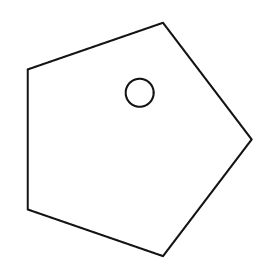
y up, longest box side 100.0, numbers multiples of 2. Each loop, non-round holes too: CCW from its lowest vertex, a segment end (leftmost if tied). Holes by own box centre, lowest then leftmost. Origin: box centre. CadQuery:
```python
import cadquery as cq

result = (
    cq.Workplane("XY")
    .moveTo(10.0, -50.0)
    .lineTo(48.0, 0.0)
    .lineTo(10.0, 50.0)
    .lineTo(-48.0, 30.0)
    .lineTo(-48.0, -30.0)
    .close()
    .moveTo(0.0, 20.0)
    .circle(6.0)
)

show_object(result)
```